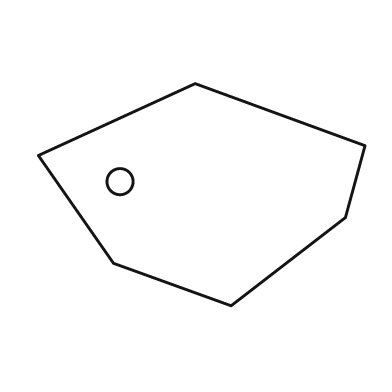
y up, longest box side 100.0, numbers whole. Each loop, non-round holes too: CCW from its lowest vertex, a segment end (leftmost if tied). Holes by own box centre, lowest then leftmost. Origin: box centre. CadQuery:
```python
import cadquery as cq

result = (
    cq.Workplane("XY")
    .moveTo(9.0, -34.0)
    .lineTo(44.0, -7.0)
    .lineTo(50.0, 15.0)
    .lineTo(-2.0, 34.0)
    .lineTo(-50.0, 12.0)
    .lineTo(-27.0, -21.0)
    .close()
    .moveTo(-25.0, 4.0)
    .circle(4.0)
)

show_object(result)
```